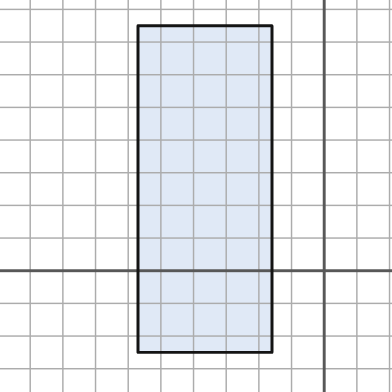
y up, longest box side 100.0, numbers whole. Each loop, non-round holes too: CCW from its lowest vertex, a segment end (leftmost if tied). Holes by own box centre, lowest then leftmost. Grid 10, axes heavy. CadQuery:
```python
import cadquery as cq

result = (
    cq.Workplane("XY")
    .moveTo(-57.0, -25.0)
    .lineTo(-16.0, -25.0)
    .lineTo(-16.0, 75.0)
    .lineTo(-57.0, 75.0)
    .close()
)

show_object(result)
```